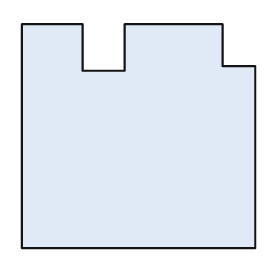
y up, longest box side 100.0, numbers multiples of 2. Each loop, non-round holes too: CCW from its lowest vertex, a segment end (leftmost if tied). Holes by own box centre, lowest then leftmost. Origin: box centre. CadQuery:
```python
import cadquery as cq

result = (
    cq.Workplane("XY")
    .moveTo(-50.0, -48.0)
    .lineTo(50.0, -48.0)
    .lineTo(50.0, 30.0)
    .lineTo(36.0, 30.0)
    .lineTo(36.0, 48.0)
    .lineTo(-6.0, 48.0)
    .lineTo(-6.0, 28.0)
    .lineTo(-24.0, 28.0)
    .lineTo(-24.0, 48.0)
    .lineTo(-50.0, 48.0)
    .close()
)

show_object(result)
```